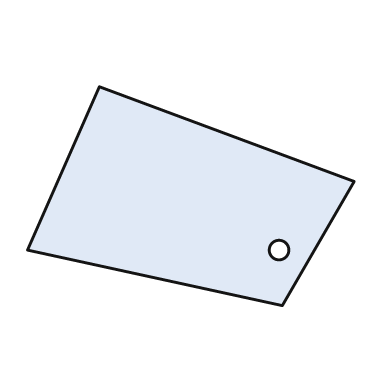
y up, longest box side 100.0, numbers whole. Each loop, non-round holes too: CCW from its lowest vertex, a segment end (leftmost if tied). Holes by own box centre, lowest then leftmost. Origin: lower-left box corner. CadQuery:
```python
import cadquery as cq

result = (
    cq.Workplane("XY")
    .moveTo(78.0, 0.0)
    .lineTo(100.0, 38.0)
    .lineTo(22.0, 67.0)
    .lineTo(0.0, 17.0)
    .close()
    .moveTo(77.0, 17.0)
    .circle(3.0)
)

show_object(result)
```